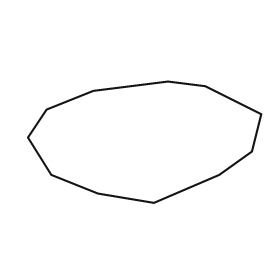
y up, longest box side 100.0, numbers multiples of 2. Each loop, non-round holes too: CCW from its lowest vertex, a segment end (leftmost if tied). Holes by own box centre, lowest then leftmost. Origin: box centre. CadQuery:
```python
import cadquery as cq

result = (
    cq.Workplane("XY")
    .moveTo(4.0, -26.0)
    .lineTo(32.0, -14.0)
    .lineTo(46.0, -4.0)
    .lineTo(50.0, 12.0)
    .lineTo(26.0, 24.0)
    .lineTo(10.0, 26.0)
    .lineTo(-22.0, 22.0)
    .lineTo(-42.0, 14.0)
    .lineTo(-50.0, 2.0)
    .lineTo(-40.0, -14.0)
    .lineTo(-20.0, -22.0)
    .close()
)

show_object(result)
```